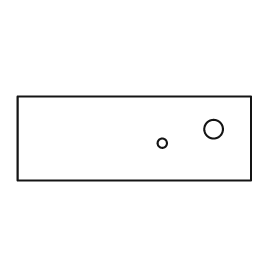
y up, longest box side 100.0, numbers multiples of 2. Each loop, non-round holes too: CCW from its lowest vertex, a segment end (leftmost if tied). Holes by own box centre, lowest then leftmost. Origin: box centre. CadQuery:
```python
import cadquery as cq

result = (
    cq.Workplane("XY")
    .moveTo(-50.0, -18.0)
    .lineTo(50.0, -18.0)
    .lineTo(50.0, 18.0)
    .lineTo(-50.0, 18.0)
    .close()
    .moveTo(12.0, -2.0)
    .circle(2.0)
    .moveTo(34.0, 4.0)
    .circle(4.0)
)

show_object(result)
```